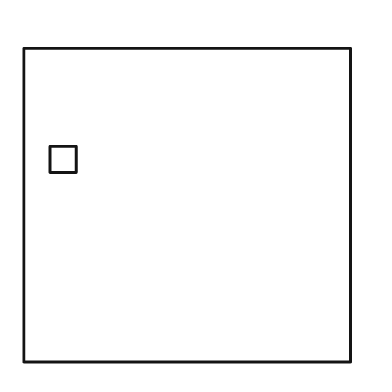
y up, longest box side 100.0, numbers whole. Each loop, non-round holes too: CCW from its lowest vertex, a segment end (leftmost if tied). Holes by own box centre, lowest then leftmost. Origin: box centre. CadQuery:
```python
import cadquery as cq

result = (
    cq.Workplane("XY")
    .moveTo(-50.0, -48.0)
    .lineTo(50.0, -48.0)
    .lineTo(50.0, 48.0)
    .lineTo(-50.0, 48.0)
    .close()
    .moveTo(-42.0, 10.0)
    .lineTo(-34.0, 10.0)
    .lineTo(-34.0, 18.0)
    .lineTo(-42.0, 18.0)
    .close()
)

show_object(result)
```